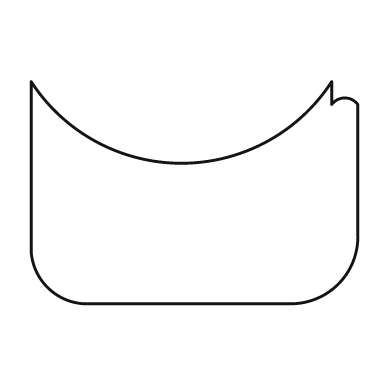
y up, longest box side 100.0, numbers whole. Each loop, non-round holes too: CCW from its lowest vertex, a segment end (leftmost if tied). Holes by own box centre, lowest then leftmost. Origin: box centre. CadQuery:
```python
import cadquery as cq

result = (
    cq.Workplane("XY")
    .moveTo(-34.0, -34.0)
    .lineTo(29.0, -34.0)
    .threePointArc((44.0, -28.0), (50.0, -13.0))
    .lineTo(50.0, 27.0)
    .threePointArc((46.0, 29.0), (42.0, 27.0))
    .lineTo(42.0, 34.0)
    .threePointArc((-4.0, 9.0), (-50.0, 34.0))
    .lineTo(-50.0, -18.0)
    .threePointArc((-45.0, -29.0), (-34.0, -34.0))
    .close()
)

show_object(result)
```